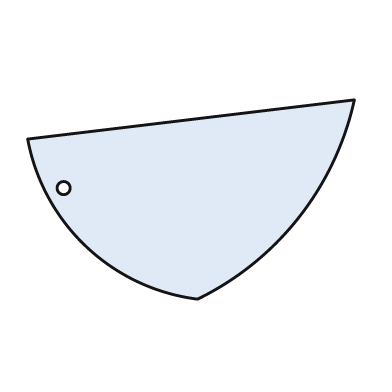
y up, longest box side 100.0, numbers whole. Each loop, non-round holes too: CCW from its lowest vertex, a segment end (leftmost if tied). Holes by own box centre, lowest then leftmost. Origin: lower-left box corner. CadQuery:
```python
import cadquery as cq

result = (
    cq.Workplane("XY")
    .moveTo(52.0, 0.0)
    .threePointArc((83.0, 25.0), (100.0, 61.0))
    .lineTo(0.0, 49.0)
    .threePointArc((18.0, 16.0), (52.0, 0.0))
    .close()
    .moveTo(11.0, 34.0)
    .circle(2.0)
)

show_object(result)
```